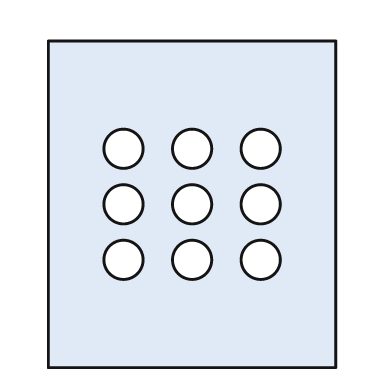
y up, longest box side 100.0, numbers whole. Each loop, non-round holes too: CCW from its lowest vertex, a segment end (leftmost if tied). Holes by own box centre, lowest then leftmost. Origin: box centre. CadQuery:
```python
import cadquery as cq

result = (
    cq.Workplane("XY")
    .moveTo(-44.0, -50.0)
    .lineTo(44.0, -50.0)
    .lineTo(44.0, 50.0)
    .lineTo(-44.0, 50.0)
    .close()
    .moveTo(-21.0, -17.0)
    .circle(6.0)
    .moveTo(0.0, -17.0)
    .circle(6.0)
    .moveTo(21.0, -17.0)
    .circle(6.0)
    .moveTo(-21.0, 0.0)
    .circle(6.0)
    .moveTo(0.0, 0.0)
    .circle(6.0)
    .moveTo(21.0, 0.0)
    .circle(6.0)
    .moveTo(-21.0, 17.0)
    .circle(6.0)
    .moveTo(0.0, 17.0)
    .circle(6.0)
    .moveTo(21.0, 17.0)
    .circle(6.0)
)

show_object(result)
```